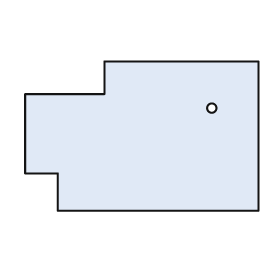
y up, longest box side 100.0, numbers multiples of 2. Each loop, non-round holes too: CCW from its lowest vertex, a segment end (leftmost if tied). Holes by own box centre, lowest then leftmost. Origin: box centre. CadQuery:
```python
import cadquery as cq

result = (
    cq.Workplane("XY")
    .moveTo(-36.0, -32.0)
    .lineTo(50.0, -32.0)
    .lineTo(50.0, 32.0)
    .lineTo(-16.0, 32.0)
    .lineTo(-16.0, 18.0)
    .lineTo(-50.0, 18.0)
    .lineTo(-50.0, -16.0)
    .lineTo(-36.0, -16.0)
    .close()
    .moveTo(30.0, 12.0)
    .circle(2.0)
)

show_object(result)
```